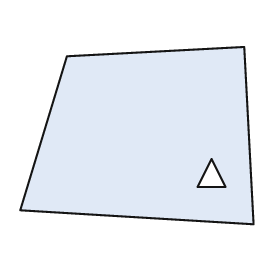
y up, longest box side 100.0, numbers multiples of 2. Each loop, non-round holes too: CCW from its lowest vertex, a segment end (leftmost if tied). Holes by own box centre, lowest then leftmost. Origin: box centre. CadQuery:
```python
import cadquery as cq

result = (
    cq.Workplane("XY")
    .moveTo(50.0, -38.0)
    .lineTo(46.0, 38.0)
    .lineTo(-30.0, 34.0)
    .lineTo(-50.0, -32.0)
    .close()
    .moveTo(26.0, -22.0)
    .lineTo(38.0, -22.0)
    .lineTo(32.0, -10.0)
    .close()
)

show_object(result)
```